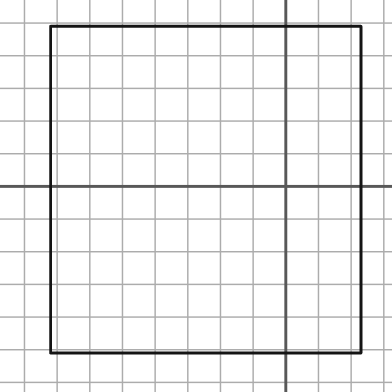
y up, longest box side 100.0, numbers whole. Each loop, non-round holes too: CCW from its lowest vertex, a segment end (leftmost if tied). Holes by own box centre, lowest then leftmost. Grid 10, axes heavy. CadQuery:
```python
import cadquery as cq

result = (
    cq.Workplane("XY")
    .moveTo(-72.0, -51.0)
    .lineTo(23.0, -51.0)
    .lineTo(23.0, 49.0)
    .lineTo(-72.0, 49.0)
    .close()
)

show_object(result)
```